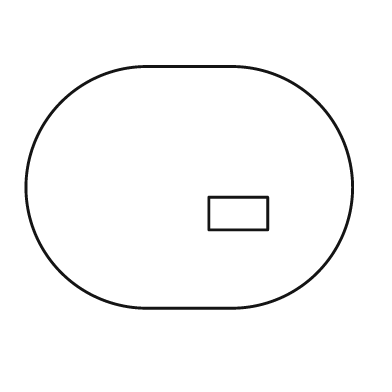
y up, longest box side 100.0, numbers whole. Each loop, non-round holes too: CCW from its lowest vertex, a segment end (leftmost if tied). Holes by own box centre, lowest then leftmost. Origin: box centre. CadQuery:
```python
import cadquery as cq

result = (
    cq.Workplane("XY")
    .moveTo(-13.0, -37.0)
    .lineTo(13.0, -37.0)
    .threePointArc((50.0, 0.0), (13.0, 37.0))
    .lineTo(-13.0, 37.0)
    .threePointArc((-50.0, 0.0), (-13.0, -37.0))
    .close()
    .moveTo(6.0, -13.0)
    .lineTo(24.0, -13.0)
    .lineTo(24.0, -3.0)
    .lineTo(6.0, -3.0)
    .close()
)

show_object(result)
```